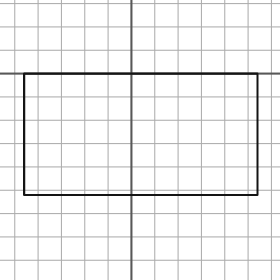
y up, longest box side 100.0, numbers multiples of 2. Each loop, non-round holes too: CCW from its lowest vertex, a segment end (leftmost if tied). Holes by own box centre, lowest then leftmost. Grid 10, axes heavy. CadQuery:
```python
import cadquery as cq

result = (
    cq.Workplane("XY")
    .moveTo(-46.0, -52.0)
    .lineTo(54.0, -52.0)
    .lineTo(54.0, 0.0)
    .lineTo(-46.0, 0.0)
    .close()
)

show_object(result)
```